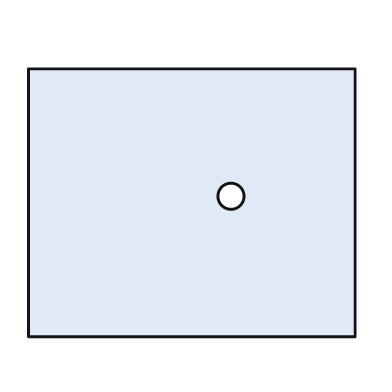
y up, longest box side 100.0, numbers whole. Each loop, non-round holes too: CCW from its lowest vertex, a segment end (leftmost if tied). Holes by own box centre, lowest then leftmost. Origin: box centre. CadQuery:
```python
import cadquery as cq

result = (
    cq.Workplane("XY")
    .moveTo(-50.0, -41.0)
    .lineTo(50.0, -41.0)
    .lineTo(50.0, 41.0)
    .lineTo(-50.0, 41.0)
    .close()
    .moveTo(12.0, 2.0)
    .circle(4.0)
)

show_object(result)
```